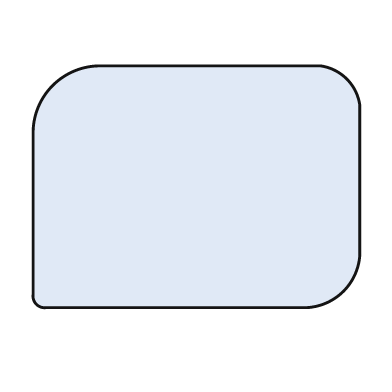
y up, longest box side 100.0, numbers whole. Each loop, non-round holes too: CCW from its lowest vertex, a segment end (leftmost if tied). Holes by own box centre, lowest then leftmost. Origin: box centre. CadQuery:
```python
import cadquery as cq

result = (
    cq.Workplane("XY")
    .moveTo(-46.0, -37.0)
    .lineTo(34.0, -37.0)
    .threePointArc((45.0, -32.0), (50.0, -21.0))
    .lineTo(50.0, 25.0)
    .threePointArc((46.0, 33.0), (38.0, 37.0))
    .lineTo(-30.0, 37.0)
    .threePointArc((-44.0, 31.0), (-50.0, 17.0))
    .lineTo(-50.0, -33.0)
    .threePointArc((-49.0, -36.0), (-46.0, -37.0))
    .close()
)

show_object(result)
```